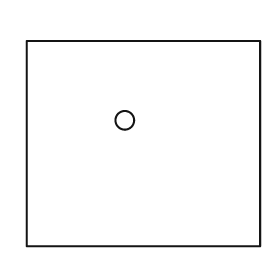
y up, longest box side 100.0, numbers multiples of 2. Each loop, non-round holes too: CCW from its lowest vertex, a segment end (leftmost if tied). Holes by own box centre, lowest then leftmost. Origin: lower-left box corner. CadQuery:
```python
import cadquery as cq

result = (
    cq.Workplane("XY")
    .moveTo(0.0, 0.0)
    .lineTo(100.0, 0.0)
    .lineTo(100.0, 88.0)
    .lineTo(0.0, 88.0)
    .close()
    .moveTo(42.0, 54.0)
    .circle(4.0)
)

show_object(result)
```